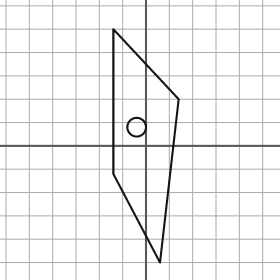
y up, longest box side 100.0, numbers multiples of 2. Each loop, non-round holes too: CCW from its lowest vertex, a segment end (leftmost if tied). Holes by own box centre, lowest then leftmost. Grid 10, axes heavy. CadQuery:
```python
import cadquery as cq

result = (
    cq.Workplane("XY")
    .moveTo(6.0, -50.0)
    .lineTo(14.0, 20.0)
    .lineTo(-14.0, 50.0)
    .lineTo(-14.0, -12.0)
    .close()
    .moveTo(-4.0, 8.0)
    .circle(4.0)
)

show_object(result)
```